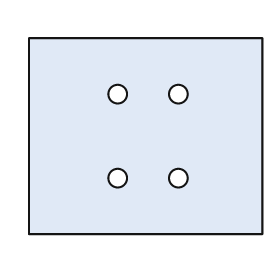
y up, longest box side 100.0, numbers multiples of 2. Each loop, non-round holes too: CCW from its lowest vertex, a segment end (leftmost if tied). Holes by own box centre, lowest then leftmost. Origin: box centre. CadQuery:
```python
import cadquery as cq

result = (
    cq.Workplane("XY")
    .moveTo(-50.0, -42.0)
    .lineTo(50.0, -42.0)
    .lineTo(50.0, 42.0)
    .lineTo(-50.0, 42.0)
    .close()
    .moveTo(-12.0, -18.0)
    .circle(4.0)
    .moveTo(14.0, -18.0)
    .circle(4.0)
    .moveTo(-12.0, 18.0)
    .circle(4.0)
    .moveTo(14.0, 18.0)
    .circle(4.0)
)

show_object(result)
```